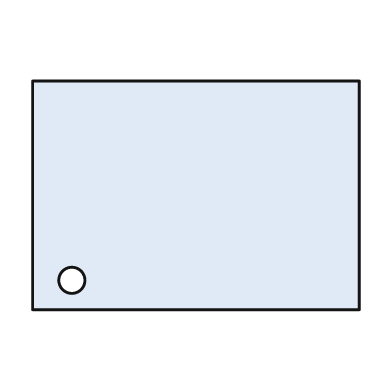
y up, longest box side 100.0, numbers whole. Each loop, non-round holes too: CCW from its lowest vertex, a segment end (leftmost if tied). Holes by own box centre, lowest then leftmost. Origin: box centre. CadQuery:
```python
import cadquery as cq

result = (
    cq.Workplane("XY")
    .moveTo(-50.0, -35.0)
    .lineTo(50.0, -35.0)
    .lineTo(50.0, 35.0)
    .lineTo(-50.0, 35.0)
    .close()
    .moveTo(-38.0, -26.0)
    .circle(4.0)
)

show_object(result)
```